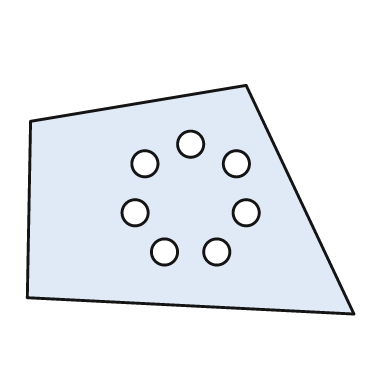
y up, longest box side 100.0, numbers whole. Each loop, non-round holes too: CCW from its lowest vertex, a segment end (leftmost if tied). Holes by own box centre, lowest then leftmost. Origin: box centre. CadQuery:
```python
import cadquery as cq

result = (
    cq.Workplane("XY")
    .moveTo(50.0, -35.0)
    .lineTo(17.0, 35.0)
    .lineTo(-49.0, 24.0)
    .lineTo(-50.0, -30.0)
    .close()
    .moveTo(-8.0, -16.0)
    .circle(4.0)
    .moveTo(8.0, -16.0)
    .circle(4.0)
    .moveTo(-17.0, -4.0)
    .circle(4.0)
    .moveTo(17.0, -4.0)
    .circle(4.0)
    .moveTo(-14.0, 11.0)
    .circle(4.0)
    .moveTo(14.0, 11.0)
    .circle(4.0)
    .moveTo(0.0, 17.0)
    .circle(4.0)
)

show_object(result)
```